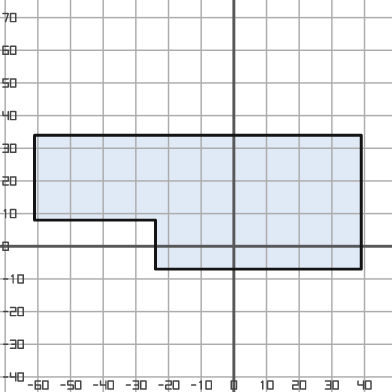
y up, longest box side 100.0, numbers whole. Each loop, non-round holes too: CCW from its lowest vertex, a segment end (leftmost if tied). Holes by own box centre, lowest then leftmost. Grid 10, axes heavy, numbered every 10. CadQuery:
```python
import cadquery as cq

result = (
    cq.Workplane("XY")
    .moveTo(-24.0, -7.0)
    .lineTo(39.0, -7.0)
    .lineTo(39.0, 34.0)
    .lineTo(-61.0, 34.0)
    .lineTo(-61.0, 8.0)
    .lineTo(-24.0, 8.0)
    .close()
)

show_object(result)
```